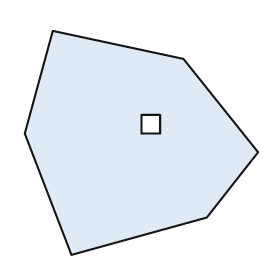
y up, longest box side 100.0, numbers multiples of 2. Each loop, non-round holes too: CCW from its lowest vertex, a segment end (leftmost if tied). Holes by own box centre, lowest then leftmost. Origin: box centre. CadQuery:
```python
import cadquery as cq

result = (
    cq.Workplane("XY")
    .moveTo(-30.0, -48.0)
    .lineTo(28.0, -32.0)
    .lineTo(50.0, -4.0)
    .lineTo(18.0, 36.0)
    .lineTo(-38.0, 48.0)
    .lineTo(-50.0, 4.0)
    .close()
    .moveTo(0.0, 4.0)
    .lineTo(8.0, 4.0)
    .lineTo(8.0, 12.0)
    .lineTo(0.0, 12.0)
    .close()
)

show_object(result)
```